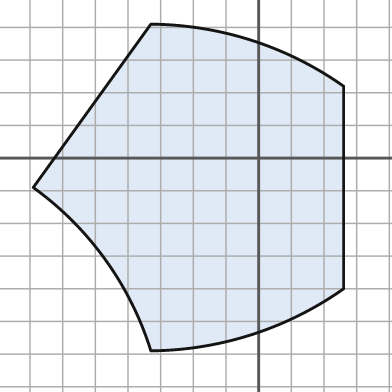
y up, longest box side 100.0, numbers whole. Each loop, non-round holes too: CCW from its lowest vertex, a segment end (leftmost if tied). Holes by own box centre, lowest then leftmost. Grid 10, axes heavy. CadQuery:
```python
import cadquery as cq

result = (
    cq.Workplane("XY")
    .moveTo(-33.0, -59.0)
    .threePointArc((-2.0, -54.0), (26.0, -40.0))
    .lineTo(26.0, 22.0)
    .threePointArc((-2.0, 36.0), (-33.0, 41.0))
    .lineTo(-69.0, -9.0)
    .threePointArc((-47.0, -31.0), (-33.0, -59.0))
    .close()
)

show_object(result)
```